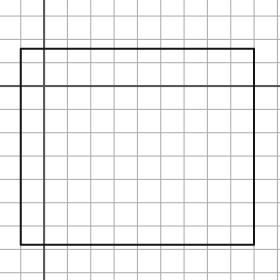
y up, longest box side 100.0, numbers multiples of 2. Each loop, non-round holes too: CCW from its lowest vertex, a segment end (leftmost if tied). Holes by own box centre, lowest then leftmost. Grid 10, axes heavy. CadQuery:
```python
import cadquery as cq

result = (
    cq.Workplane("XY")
    .moveTo(-10.0, -68.0)
    .lineTo(90.0, -68.0)
    .lineTo(90.0, 16.0)
    .lineTo(-10.0, 16.0)
    .close()
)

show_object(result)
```